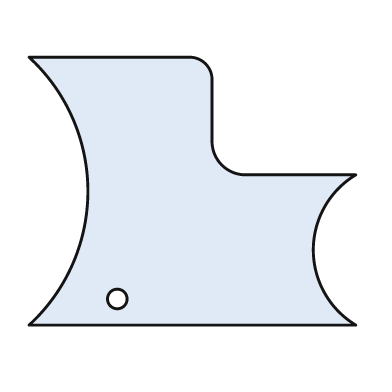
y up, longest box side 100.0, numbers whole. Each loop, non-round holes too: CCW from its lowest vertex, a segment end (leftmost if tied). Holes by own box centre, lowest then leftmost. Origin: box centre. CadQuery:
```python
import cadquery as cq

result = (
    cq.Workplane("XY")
    .moveTo(-50.0, -41.0)
    .lineTo(50.0, -41.0)
    .threePointArc((37.0, -18.0), (50.0, 5.0))
    .lineTo(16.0, 5.0)
    .threePointArc((9.0, 8.0), (6.0, 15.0))
    .lineTo(6.0, 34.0)
    .threePointArc((4.0, 39.0), (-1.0, 41.0))
    .lineTo(-50.0, 41.0)
    .threePointArc((-32.0, 0.0), (-50.0, -41.0))
    .close()
    .moveTo(-23.0, -33.0)
    .circle(3.0)
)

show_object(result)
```